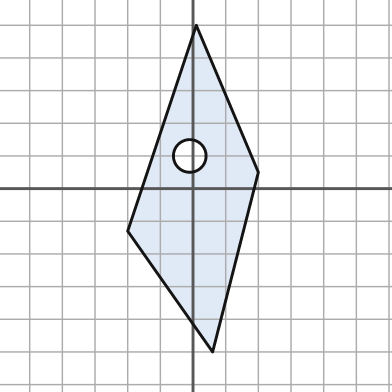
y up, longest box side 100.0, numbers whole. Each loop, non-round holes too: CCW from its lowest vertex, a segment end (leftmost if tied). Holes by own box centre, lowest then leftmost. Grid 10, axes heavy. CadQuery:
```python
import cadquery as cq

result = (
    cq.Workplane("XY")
    .moveTo(6.0, -50.0)
    .lineTo(20.0, 5.0)
    .lineTo(1.0, 50.0)
    .lineTo(-20.0, -13.0)
    .close()
    .moveTo(-1.0, 10.0)
    .circle(5.0)
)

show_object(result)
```